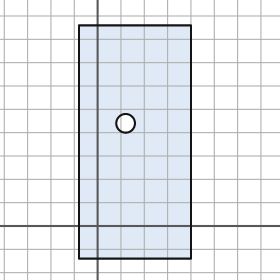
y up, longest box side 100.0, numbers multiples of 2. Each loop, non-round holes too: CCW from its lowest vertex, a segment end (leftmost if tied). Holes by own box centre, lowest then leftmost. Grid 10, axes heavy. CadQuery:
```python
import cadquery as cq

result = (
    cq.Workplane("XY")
    .moveTo(-8.0, -14.0)
    .lineTo(40.0, -14.0)
    .lineTo(40.0, 86.0)
    .lineTo(-8.0, 86.0)
    .close()
    .moveTo(12.0, 44.0)
    .circle(4.0)
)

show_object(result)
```